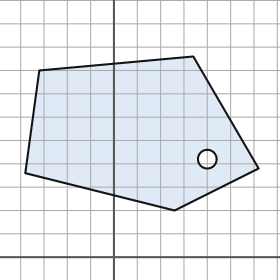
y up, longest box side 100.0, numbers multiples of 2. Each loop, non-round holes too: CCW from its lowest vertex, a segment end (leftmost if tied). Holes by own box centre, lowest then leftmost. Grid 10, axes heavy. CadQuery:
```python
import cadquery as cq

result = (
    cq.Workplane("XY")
    .moveTo(26.0, 20.0)
    .lineTo(62.0, 38.0)
    .lineTo(34.0, 86.0)
    .lineTo(-32.0, 80.0)
    .lineTo(-38.0, 36.0)
    .close()
    .moveTo(40.0, 42.0)
    .circle(4.0)
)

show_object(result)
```